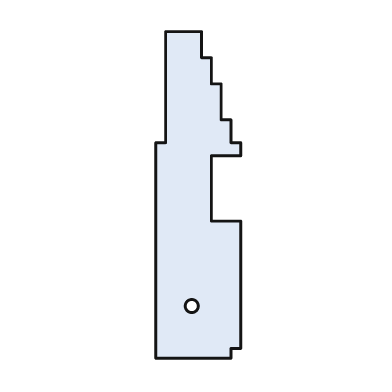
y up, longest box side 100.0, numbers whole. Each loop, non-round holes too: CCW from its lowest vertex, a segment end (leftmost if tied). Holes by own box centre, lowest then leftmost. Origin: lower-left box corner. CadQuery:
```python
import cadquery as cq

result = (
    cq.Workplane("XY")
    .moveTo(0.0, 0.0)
    .lineTo(23.0, 0.0)
    .lineTo(23.0, 3.0)
    .lineTo(26.0, 3.0)
    .lineTo(26.0, 42.0)
    .lineTo(17.0, 42.0)
    .lineTo(17.0, 62.0)
    .lineTo(26.0, 62.0)
    .lineTo(26.0, 66.0)
    .lineTo(23.0, 66.0)
    .lineTo(23.0, 73.0)
    .lineTo(20.0, 73.0)
    .lineTo(20.0, 84.0)
    .lineTo(17.0, 84.0)
    .lineTo(17.0, 92.0)
    .lineTo(14.0, 92.0)
    .lineTo(14.0, 100.0)
    .lineTo(3.0, 100.0)
    .lineTo(3.0, 66.0)
    .lineTo(0.0, 66.0)
    .close()
    .moveTo(11.0, 16.0)
    .circle(2.0)
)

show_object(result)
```